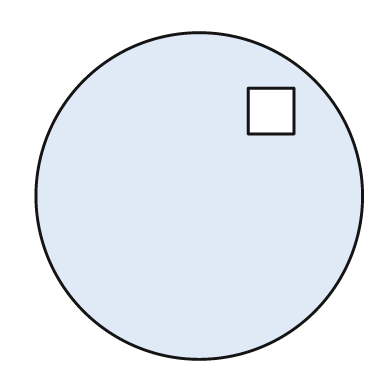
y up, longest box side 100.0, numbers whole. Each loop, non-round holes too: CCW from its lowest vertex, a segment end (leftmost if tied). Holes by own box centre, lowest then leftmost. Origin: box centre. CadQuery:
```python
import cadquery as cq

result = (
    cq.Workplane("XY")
    .moveTo(0.0, 0.0)
    .circle(50.0)
    .moveTo(15.0, 19.0)
    .lineTo(29.0, 19.0)
    .lineTo(29.0, 33.0)
    .lineTo(15.0, 33.0)
    .close()
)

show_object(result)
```